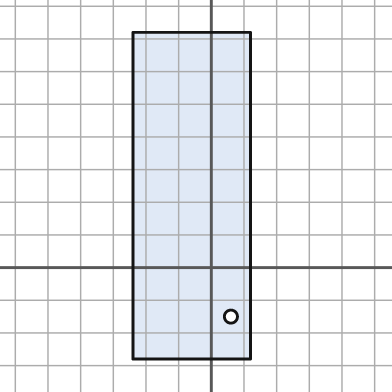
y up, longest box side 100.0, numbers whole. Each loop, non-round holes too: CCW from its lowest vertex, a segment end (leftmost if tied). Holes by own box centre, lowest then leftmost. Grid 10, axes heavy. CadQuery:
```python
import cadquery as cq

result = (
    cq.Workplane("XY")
    .moveTo(-24.0, -28.0)
    .lineTo(12.0, -28.0)
    .lineTo(12.0, 72.0)
    .lineTo(-24.0, 72.0)
    .close()
    .moveTo(6.0, -15.0)
    .circle(2.0)
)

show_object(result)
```